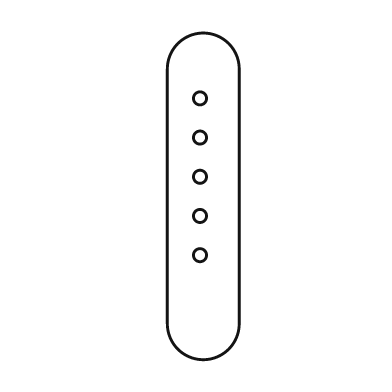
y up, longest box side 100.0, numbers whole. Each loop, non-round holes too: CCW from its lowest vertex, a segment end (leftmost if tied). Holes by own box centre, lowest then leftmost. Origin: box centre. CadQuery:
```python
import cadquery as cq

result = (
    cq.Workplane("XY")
    .moveTo(-11.0, -39.0)
    .threePointArc((0.0, -50.0), (11.0, -39.0))
    .lineTo(11.0, 39.0)
    .threePointArc((0.0, 50.0), (-11.0, 39.0))
    .close()
    .moveTo(-1.0, -18.0)
    .circle(2.0)
    .moveTo(-1.0, -6.0)
    .circle(2.0)
    .moveTo(-1.0, 6.0)
    .circle(2.0)
    .moveTo(-1.0, 18.0)
    .circle(2.0)
    .moveTo(-1.0, 30.0)
    .circle(2.0)
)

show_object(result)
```